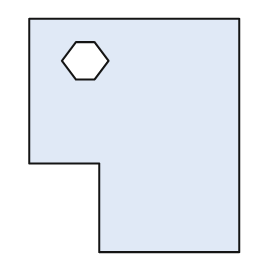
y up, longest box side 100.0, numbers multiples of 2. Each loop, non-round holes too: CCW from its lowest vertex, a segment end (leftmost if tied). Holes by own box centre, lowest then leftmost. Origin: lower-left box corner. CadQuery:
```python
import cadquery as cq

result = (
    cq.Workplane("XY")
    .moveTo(30.0, 0.0)
    .lineTo(90.0, 0.0)
    .lineTo(90.0, 100.0)
    .lineTo(0.0, 100.0)
    .lineTo(0.0, 38.0)
    .lineTo(30.0, 38.0)
    .close()
    .moveTo(20.0, 74.0)
    .lineTo(28.0, 74.0)
    .lineTo(34.0, 82.0)
    .lineTo(28.0, 90.0)
    .lineTo(20.0, 90.0)
    .lineTo(14.0, 82.0)
    .close()
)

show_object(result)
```